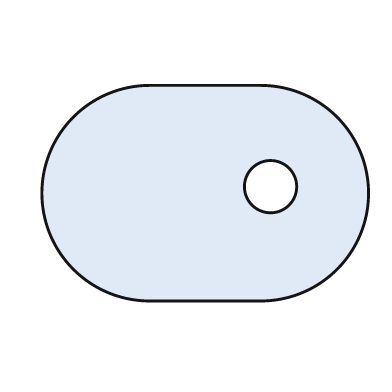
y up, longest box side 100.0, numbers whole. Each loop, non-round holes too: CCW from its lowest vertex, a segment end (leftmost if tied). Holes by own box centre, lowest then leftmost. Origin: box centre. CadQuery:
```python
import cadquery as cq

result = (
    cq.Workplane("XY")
    .moveTo(-17.0, -33.0)
    .lineTo(17.0, -33.0)
    .threePointArc((50.0, 0.0), (17.0, 33.0))
    .lineTo(-17.0, 33.0)
    .threePointArc((-50.0, 0.0), (-17.0, -33.0))
    .close()
    .moveTo(20.0, 2.0)
    .circle(8.0)
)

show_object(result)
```